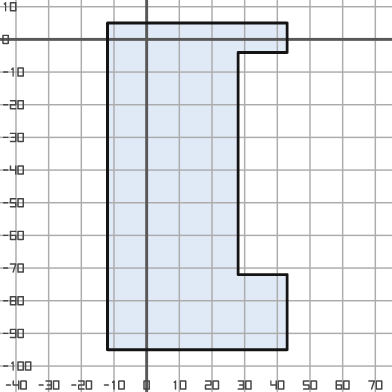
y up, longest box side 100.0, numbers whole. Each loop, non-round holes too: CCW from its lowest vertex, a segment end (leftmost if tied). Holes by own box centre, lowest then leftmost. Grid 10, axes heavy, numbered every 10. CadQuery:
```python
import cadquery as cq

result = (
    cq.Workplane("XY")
    .moveTo(-12.0, -95.0)
    .lineTo(43.0, -95.0)
    .lineTo(43.0, -72.0)
    .lineTo(28.0, -72.0)
    .lineTo(28.0, -4.0)
    .lineTo(43.0, -4.0)
    .lineTo(43.0, 5.0)
    .lineTo(-12.0, 5.0)
    .close()
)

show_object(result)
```